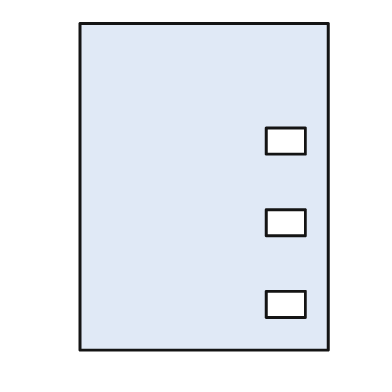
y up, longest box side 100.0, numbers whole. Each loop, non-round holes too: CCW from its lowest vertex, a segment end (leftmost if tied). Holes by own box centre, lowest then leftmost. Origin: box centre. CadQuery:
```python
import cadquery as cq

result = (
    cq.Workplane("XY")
    .moveTo(-38.0, -50.0)
    .lineTo(38.0, -50.0)
    .lineTo(38.0, 50.0)
    .lineTo(-38.0, 50.0)
    .close()
    .moveTo(19.0, -40.0)
    .lineTo(31.0, -40.0)
    .lineTo(31.0, -32.0)
    .lineTo(19.0, -32.0)
    .close()
    .moveTo(19.0, -15.0)
    .lineTo(31.0, -15.0)
    .lineTo(31.0, -7.0)
    .lineTo(19.0, -7.0)
    .close()
    .moveTo(19.0, 10.0)
    .lineTo(31.0, 10.0)
    .lineTo(31.0, 18.0)
    .lineTo(19.0, 18.0)
    .close()
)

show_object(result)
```